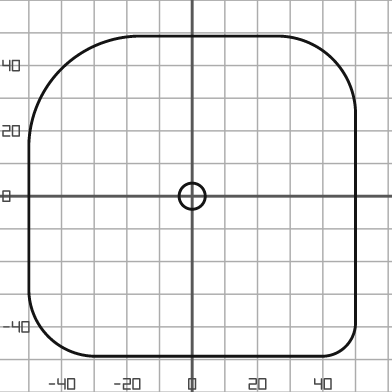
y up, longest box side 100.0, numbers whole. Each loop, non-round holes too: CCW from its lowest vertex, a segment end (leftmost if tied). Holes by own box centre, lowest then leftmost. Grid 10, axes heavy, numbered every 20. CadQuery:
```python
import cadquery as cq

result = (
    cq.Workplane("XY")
    .moveTo(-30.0, -49.0)
    .lineTo(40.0, -49.0)
    .threePointArc((47.0, -46.0), (50.0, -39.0))
    .lineTo(50.0, 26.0)
    .threePointArc((43.0, 42.0), (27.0, 49.0))
    .lineTo(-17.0, 49.0)
    .threePointArc((-40.0, 39.0), (-50.0, 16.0))
    .lineTo(-50.0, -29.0)
    .threePointArc((-44.0, -43.0), (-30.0, -49.0))
    .close()
    .moveTo(0.0, 0.0)
    .circle(4.0)
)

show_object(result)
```